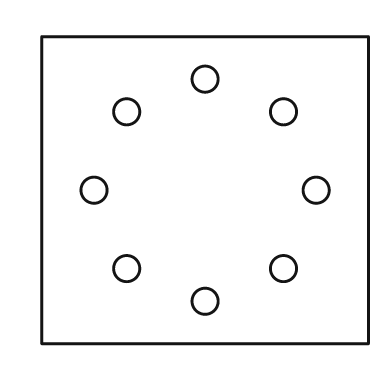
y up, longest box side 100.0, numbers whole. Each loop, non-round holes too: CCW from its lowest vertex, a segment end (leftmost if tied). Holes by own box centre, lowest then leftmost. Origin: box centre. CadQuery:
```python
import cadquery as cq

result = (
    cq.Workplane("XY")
    .moveTo(-50.0, -47.0)
    .lineTo(50.0, -47.0)
    .lineTo(50.0, 47.0)
    .lineTo(-50.0, 47.0)
    .close()
    .moveTo(0.0, -34.0)
    .circle(4.0)
    .moveTo(-24.0, -24.0)
    .circle(4.0)
    .moveTo(24.0, -24.0)
    .circle(4.0)
    .moveTo(-34.0, 0.0)
    .circle(4.0)
    .moveTo(34.0, 0.0)
    .circle(4.0)
    .moveTo(-24.0, 24.0)
    .circle(4.0)
    .moveTo(24.0, 24.0)
    .circle(4.0)
    .moveTo(0.0, 34.0)
    .circle(4.0)
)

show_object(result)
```